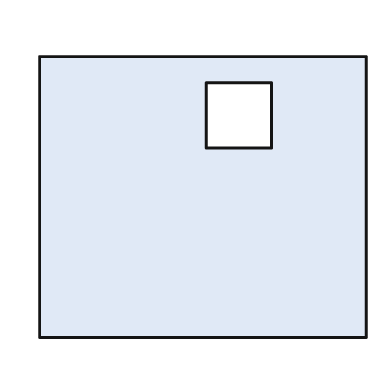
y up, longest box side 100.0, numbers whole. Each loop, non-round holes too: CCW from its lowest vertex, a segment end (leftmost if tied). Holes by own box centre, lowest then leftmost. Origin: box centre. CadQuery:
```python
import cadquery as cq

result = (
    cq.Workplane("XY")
    .moveTo(-50.0, -43.0)
    .lineTo(50.0, -43.0)
    .lineTo(50.0, 43.0)
    .lineTo(-50.0, 43.0)
    .close()
    .moveTo(1.0, 15.0)
    .lineTo(21.0, 15.0)
    .lineTo(21.0, 35.0)
    .lineTo(1.0, 35.0)
    .close()
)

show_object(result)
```